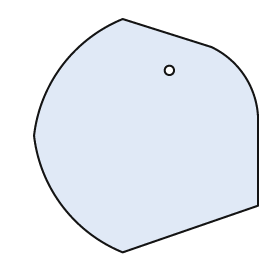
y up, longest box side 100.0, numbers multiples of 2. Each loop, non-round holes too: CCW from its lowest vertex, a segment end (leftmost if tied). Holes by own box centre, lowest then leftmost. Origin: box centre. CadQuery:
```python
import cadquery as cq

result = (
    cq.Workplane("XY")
    .moveTo(-10.0, -50.0)
    .lineTo(48.0, -30.0)
    .lineTo(48.0, 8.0)
    .threePointArc((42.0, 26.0), (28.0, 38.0))
    .lineTo(-10.0, 50.0)
    .threePointArc((-36.0, 30.0), (-48.0, 0.0))
    .threePointArc((-36.0, -30.0), (-10.0, -50.0))
    .close()
    .moveTo(10.0, 28.0)
    .circle(2.0)
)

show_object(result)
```